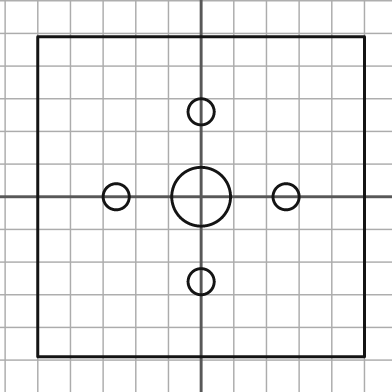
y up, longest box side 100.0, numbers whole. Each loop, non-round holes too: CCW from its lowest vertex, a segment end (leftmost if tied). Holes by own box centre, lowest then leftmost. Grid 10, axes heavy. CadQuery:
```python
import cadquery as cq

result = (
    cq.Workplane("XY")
    .moveTo(-50.0, -49.0)
    .lineTo(50.0, -49.0)
    .lineTo(50.0, 49.0)
    .lineTo(-50.0, 49.0)
    .close()
    .moveTo(0.0, -26.0)
    .circle(4.0)
    .moveTo(-26.0, 0.0)
    .circle(4.0)
    .moveTo(0.0, 0.0)
    .circle(9.0)
    .moveTo(26.0, 0.0)
    .circle(4.0)
    .moveTo(0.0, 26.0)
    .circle(4.0)
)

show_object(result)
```